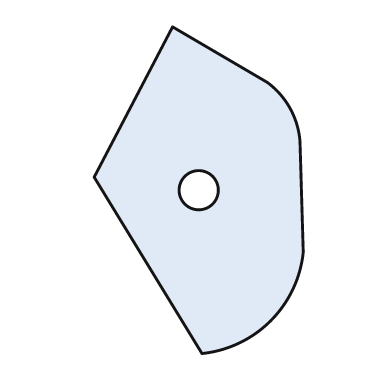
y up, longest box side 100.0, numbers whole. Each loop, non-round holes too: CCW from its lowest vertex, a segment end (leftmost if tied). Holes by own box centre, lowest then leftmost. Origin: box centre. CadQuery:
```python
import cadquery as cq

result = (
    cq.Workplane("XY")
    .moveTo(1.0, -50.0)
    .threePointArc((22.0, -40.0), (32.0, -19.0))
    .lineTo(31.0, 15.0)
    .threePointArc((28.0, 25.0), (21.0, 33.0))
    .lineTo(-8.0, 50.0)
    .lineTo(-32.0, 4.0)
    .close()
    .moveTo(0.0, 0.0)
    .circle(6.0)
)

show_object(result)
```